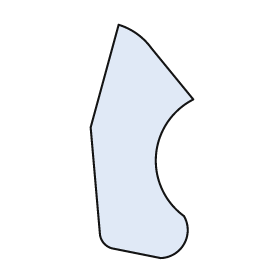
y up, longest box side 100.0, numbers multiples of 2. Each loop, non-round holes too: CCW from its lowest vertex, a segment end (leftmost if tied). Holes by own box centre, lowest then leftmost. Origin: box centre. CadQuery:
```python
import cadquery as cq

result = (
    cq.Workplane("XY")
    .moveTo(8.0, -50.0)
    .threePointArc((18.0, -44.0), (18.0, -32.0))
    .threePointArc((6.0, -6.0), (22.0, 18.0))
    .lineTo(4.0, 40.0)
    .threePointArc((-2.0, 46.0), (-10.0, 50.0))
    .lineTo(-22.0, 6.0)
    .lineTo(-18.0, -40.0)
    .threePointArc((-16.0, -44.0), (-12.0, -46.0))
    .close()
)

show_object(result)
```